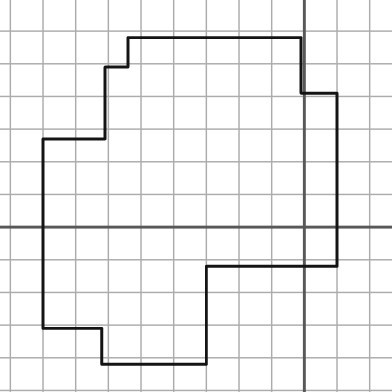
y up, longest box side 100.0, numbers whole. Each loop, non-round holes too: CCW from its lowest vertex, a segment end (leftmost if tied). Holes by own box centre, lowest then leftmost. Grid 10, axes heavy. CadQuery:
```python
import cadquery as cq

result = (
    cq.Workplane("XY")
    .moveTo(-62.0, -42.0)
    .lineTo(-30.0, -42.0)
    .lineTo(-30.0, -12.0)
    .lineTo(10.0, -12.0)
    .lineTo(10.0, 41.0)
    .lineTo(-1.0, 41.0)
    .lineTo(-1.0, 58.0)
    .lineTo(-54.0, 58.0)
    .lineTo(-54.0, 49.0)
    .lineTo(-61.0, 49.0)
    .lineTo(-61.0, 27.0)
    .lineTo(-80.0, 27.0)
    .lineTo(-80.0, -31.0)
    .lineTo(-62.0, -31.0)
    .close()
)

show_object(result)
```